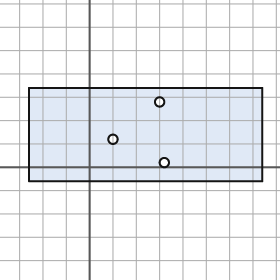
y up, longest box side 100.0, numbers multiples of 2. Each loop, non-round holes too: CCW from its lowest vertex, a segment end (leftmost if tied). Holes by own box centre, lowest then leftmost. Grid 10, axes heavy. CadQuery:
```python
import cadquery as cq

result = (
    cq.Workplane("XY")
    .moveTo(-26.0, -6.0)
    .lineTo(74.0, -6.0)
    .lineTo(74.0, 34.0)
    .lineTo(-26.0, 34.0)
    .close()
    .moveTo(32.0, 2.0)
    .circle(2.0)
    .moveTo(10.0, 12.0)
    .circle(2.0)
    .moveTo(30.0, 28.0)
    .circle(2.0)
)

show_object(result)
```